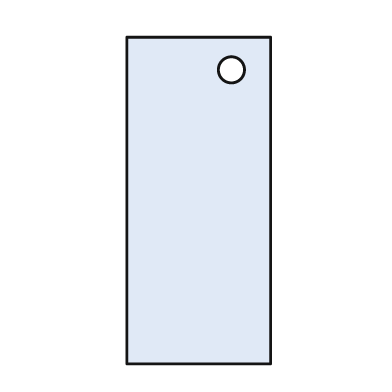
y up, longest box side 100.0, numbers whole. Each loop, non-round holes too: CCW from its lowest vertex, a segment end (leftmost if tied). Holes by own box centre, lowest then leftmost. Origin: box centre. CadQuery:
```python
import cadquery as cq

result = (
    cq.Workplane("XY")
    .moveTo(-22.0, -50.0)
    .lineTo(22.0, -50.0)
    .lineTo(22.0, 50.0)
    .lineTo(-22.0, 50.0)
    .close()
    .moveTo(10.0, 40.0)
    .circle(4.0)
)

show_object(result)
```